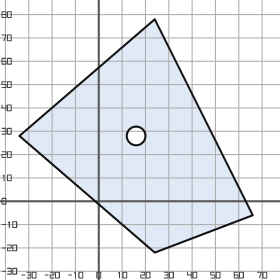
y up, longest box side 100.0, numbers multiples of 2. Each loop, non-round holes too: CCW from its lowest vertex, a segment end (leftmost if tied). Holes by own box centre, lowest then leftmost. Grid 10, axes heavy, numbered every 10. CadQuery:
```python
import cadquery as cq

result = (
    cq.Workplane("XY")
    .moveTo(24.0, -22.0)
    .lineTo(66.0, -6.0)
    .lineTo(24.0, 78.0)
    .lineTo(-34.0, 28.0)
    .close()
    .moveTo(16.0, 28.0)
    .circle(4.0)
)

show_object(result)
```